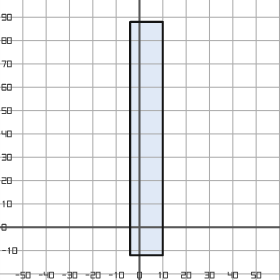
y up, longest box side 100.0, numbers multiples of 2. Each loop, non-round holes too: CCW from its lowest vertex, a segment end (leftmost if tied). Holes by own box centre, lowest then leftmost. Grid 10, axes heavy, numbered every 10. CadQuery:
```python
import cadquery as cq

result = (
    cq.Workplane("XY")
    .moveTo(-4.0, -12.0)
    .lineTo(10.0, -12.0)
    .lineTo(10.0, 88.0)
    .lineTo(-4.0, 88.0)
    .close()
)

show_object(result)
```